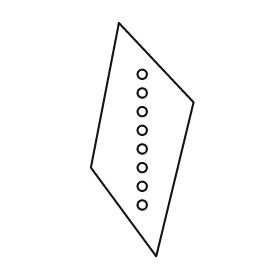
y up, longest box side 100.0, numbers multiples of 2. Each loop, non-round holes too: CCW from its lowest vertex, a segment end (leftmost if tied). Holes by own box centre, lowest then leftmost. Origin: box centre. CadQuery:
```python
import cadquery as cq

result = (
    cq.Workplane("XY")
    .moveTo(6.0, -50.0)
    .lineTo(22.0, 16.0)
    .lineTo(-10.0, 50.0)
    .lineTo(-22.0, -12.0)
    .close()
    .moveTo(0.0, -28.0)
    .circle(2.0)
    .moveTo(0.0, -20.0)
    .circle(2.0)
    .moveTo(0.0, -12.0)
    .circle(2.0)
    .moveTo(0.0, -4.0)
    .circle(2.0)
    .moveTo(0.0, 4.0)
    .circle(2.0)
    .moveTo(0.0, 12.0)
    .circle(2.0)
    .moveTo(0.0, 20.0)
    .circle(2.0)
    .moveTo(0.0, 28.0)
    .circle(2.0)
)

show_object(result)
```